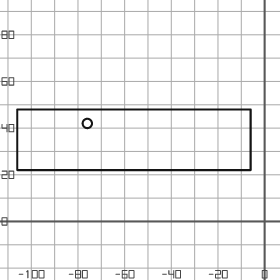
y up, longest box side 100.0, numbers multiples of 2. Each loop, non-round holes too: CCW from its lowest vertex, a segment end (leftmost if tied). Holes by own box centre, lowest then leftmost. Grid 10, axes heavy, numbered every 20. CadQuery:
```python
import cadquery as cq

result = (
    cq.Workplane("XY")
    .moveTo(-106.0, 22.0)
    .lineTo(-6.0, 22.0)
    .lineTo(-6.0, 48.0)
    .lineTo(-106.0, 48.0)
    .close()
    .moveTo(-76.0, 42.0)
    .circle(2.0)
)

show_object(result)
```